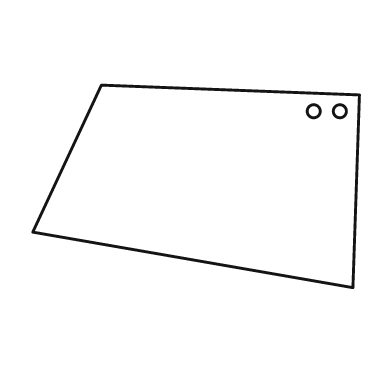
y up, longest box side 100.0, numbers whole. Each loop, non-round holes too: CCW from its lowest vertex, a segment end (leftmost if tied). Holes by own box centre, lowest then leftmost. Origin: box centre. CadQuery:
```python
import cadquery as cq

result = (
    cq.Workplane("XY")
    .moveTo(48.0, -31.0)
    .lineTo(50.0, 28.0)
    .lineTo(-29.0, 31.0)
    .lineTo(-50.0, -14.0)
    .close()
    .moveTo(36.0, 23.0)
    .circle(2.0)
    .moveTo(44.0, 23.0)
    .circle(2.0)
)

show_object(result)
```